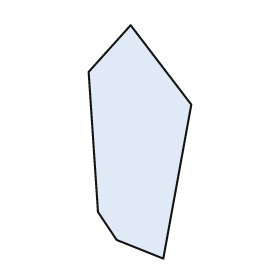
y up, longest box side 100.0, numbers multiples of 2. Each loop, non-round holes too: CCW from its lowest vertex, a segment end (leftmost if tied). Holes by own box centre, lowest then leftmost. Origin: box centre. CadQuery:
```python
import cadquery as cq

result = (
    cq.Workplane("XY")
    .moveTo(10.0, -50.0)
    .lineTo(22.0, 16.0)
    .lineTo(-4.0, 50.0)
    .lineTo(-22.0, 30.0)
    .lineTo(-18.0, -30.0)
    .lineTo(-10.0, -42.0)
    .close()
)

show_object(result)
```